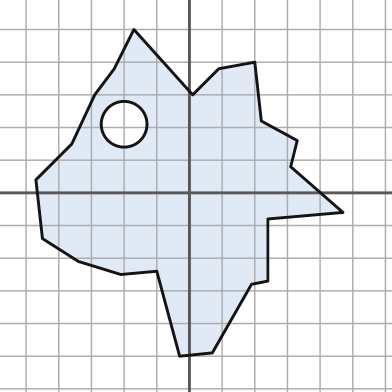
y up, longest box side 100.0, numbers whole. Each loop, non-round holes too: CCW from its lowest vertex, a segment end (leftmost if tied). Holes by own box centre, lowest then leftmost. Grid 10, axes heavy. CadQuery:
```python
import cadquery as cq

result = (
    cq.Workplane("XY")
    .moveTo(-3.0, -50.0)
    .lineTo(7.0, -49.0)
    .lineTo(19.0, -28.0)
    .lineTo(24.0, -27.0)
    .lineTo(24.0, -8.0)
    .lineTo(47.0, -6.0)
    .lineTo(31.0, 8.0)
    .lineTo(33.0, 16.0)
    .lineTo(22.0, 22.0)
    .lineTo(20.0, 40.0)
    .lineTo(9.0, 38.0)
    .lineTo(1.0, 30.0)
    .lineTo(-17.0, 50.0)
    .lineTo(-23.0, 38.0)
    .lineTo(-29.0, 30.0)
    .lineTo(-36.0, 15.0)
    .lineTo(-47.0, 4.0)
    .lineTo(-45.0, -14.0)
    .lineTo(-34.0, -21.0)
    .lineTo(-21.0, -25.0)
    .lineTo(-10.0, -24.0)
    .close()
    .moveTo(-20.0, 21.0)
    .circle(7.0)
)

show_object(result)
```